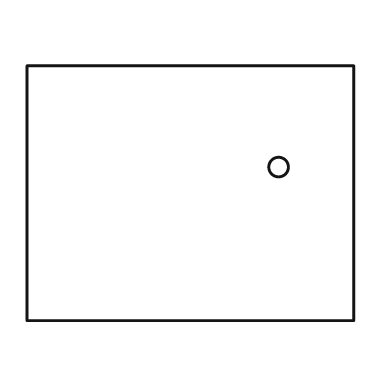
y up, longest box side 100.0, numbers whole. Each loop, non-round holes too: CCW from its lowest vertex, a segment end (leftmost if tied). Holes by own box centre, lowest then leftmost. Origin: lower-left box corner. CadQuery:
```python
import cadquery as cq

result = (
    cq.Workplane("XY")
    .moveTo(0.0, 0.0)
    .lineTo(100.0, 0.0)
    .lineTo(100.0, 78.0)
    .lineTo(0.0, 78.0)
    .close()
    .moveTo(77.0, 47.0)
    .circle(3.0)
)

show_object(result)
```